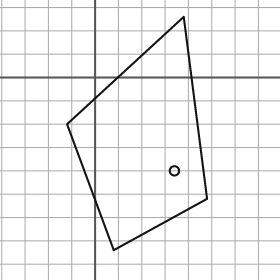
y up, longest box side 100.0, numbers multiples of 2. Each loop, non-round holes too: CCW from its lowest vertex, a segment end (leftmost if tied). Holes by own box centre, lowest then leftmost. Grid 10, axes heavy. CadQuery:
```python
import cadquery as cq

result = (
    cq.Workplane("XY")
    .moveTo(8.0, -74.0)
    .lineTo(48.0, -52.0)
    .lineTo(38.0, 26.0)
    .lineTo(-12.0, -20.0)
    .close()
    .moveTo(34.0, -40.0)
    .circle(2.0)
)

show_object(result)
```